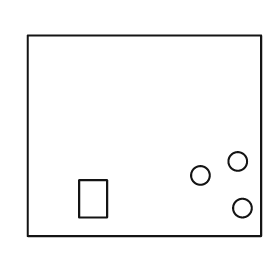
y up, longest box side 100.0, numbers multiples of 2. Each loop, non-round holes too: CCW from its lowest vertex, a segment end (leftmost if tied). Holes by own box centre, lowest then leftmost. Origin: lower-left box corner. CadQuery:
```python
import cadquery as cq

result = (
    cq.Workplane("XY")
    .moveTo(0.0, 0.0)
    .lineTo(100.0, 0.0)
    .lineTo(100.0, 86.0)
    .lineTo(0.0, 86.0)
    .close()
    .moveTo(92.0, 12.0)
    .circle(4.0)
    .moveTo(22.0, 8.0)
    .lineTo(34.0, 8.0)
    .lineTo(34.0, 24.0)
    .lineTo(22.0, 24.0)
    .close()
    .moveTo(74.0, 26.0)
    .circle(4.0)
    .moveTo(90.0, 32.0)
    .circle(4.0)
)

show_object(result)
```